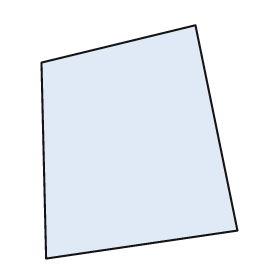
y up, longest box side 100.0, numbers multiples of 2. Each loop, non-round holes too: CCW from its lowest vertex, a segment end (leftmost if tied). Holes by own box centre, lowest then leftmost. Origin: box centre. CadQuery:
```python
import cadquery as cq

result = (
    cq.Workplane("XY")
    .moveTo(-40.0, -50.0)
    .lineTo(42.0, -38.0)
    .lineTo(24.0, 50.0)
    .lineTo(-42.0, 34.0)
    .close()
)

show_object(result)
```